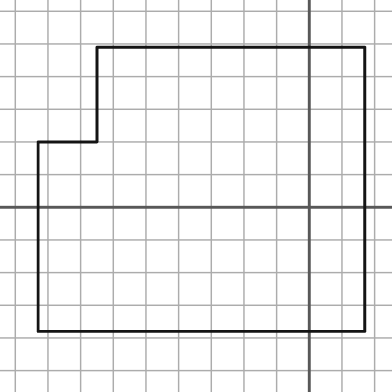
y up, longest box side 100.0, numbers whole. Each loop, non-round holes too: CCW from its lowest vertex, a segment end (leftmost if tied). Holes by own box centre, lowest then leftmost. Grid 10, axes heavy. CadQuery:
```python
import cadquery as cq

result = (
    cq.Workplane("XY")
    .moveTo(-83.0, -38.0)
    .lineTo(17.0, -38.0)
    .lineTo(17.0, 49.0)
    .lineTo(-65.0, 49.0)
    .lineTo(-65.0, 20.0)
    .lineTo(-83.0, 20.0)
    .close()
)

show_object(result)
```